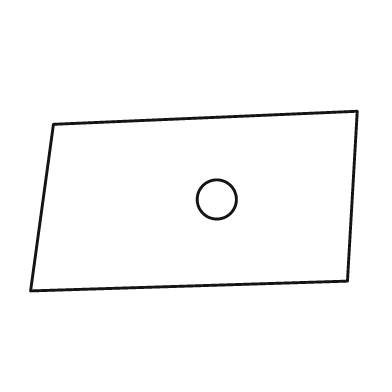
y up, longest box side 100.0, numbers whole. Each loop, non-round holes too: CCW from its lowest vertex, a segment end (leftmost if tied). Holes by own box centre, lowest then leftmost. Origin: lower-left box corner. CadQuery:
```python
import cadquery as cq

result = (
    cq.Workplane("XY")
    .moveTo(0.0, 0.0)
    .lineTo(97.0, 3.0)
    .lineTo(100.0, 55.0)
    .lineTo(7.0, 51.0)
    .close()
    .moveTo(57.0, 28.0)
    .circle(6.0)
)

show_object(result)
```